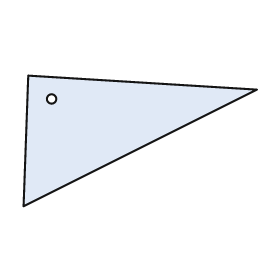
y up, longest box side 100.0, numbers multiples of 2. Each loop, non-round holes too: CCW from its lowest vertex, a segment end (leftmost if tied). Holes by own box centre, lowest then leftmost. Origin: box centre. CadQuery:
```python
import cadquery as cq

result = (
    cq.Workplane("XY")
    .moveTo(-50.0, -28.0)
    .lineTo(50.0, 22.0)
    .lineTo(-48.0, 28.0)
    .close()
    .moveTo(-38.0, 18.0)
    .circle(2.0)
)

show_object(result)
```